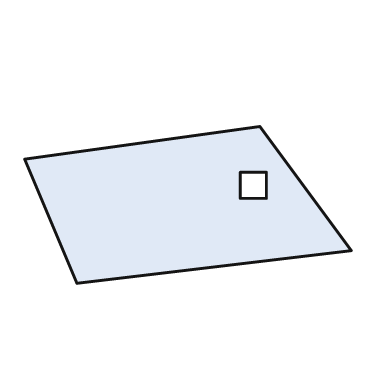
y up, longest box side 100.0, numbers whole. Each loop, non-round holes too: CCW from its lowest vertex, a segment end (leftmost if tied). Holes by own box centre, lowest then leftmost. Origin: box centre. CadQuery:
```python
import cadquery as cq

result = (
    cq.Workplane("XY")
    .moveTo(-34.0, -24.0)
    .lineTo(50.0, -14.0)
    .lineTo(22.0, 24.0)
    .lineTo(-50.0, 14.0)
    .close()
    .moveTo(16.0, 2.0)
    .lineTo(24.0, 2.0)
    .lineTo(24.0, 10.0)
    .lineTo(16.0, 10.0)
    .close()
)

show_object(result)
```